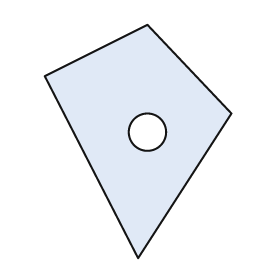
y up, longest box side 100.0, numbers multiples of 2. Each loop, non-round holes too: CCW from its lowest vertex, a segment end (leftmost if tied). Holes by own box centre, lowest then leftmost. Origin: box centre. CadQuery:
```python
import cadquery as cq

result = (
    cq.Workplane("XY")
    .moveTo(0.0, -50.0)
    .lineTo(40.0, 12.0)
    .lineTo(4.0, 50.0)
    .lineTo(-40.0, 28.0)
    .close()
    .moveTo(4.0, 4.0)
    .circle(8.0)
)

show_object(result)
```